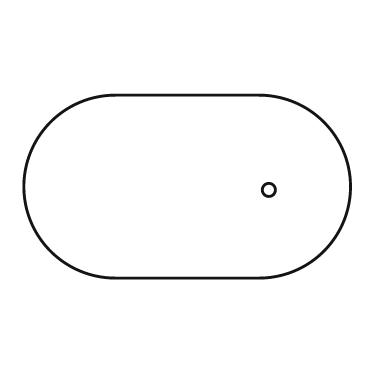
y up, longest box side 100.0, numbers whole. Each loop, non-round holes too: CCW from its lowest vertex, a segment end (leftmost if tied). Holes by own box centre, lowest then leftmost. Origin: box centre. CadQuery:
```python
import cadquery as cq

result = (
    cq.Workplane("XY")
    .moveTo(-22.0, -28.0)
    .lineTo(22.0, -28.0)
    .threePointArc((50.0, 0.0), (22.0, 28.0))
    .lineTo(-22.0, 28.0)
    .threePointArc((-50.0, 0.0), (-22.0, -28.0))
    .close()
    .moveTo(25.0, -1.0)
    .circle(2.0)
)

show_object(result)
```